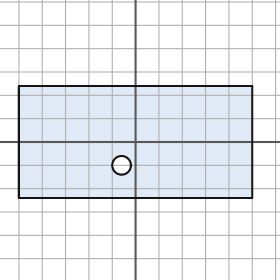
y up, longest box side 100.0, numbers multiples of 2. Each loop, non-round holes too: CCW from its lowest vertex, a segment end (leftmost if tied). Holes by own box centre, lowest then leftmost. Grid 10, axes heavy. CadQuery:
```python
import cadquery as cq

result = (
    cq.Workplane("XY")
    .moveTo(-50.0, -24.0)
    .lineTo(50.0, -24.0)
    .lineTo(50.0, 24.0)
    .lineTo(-50.0, 24.0)
    .close()
    .moveTo(-6.0, -10.0)
    .circle(4.0)
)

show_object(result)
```